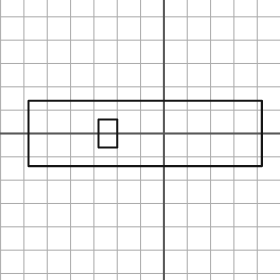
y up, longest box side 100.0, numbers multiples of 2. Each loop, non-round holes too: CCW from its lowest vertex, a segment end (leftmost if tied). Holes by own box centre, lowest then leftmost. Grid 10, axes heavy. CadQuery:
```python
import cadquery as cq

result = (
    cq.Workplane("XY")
    .moveTo(-58.0, -14.0)
    .lineTo(42.0, -14.0)
    .lineTo(42.0, 14.0)
    .lineTo(-58.0, 14.0)
    .close()
    .moveTo(-28.0, -6.0)
    .lineTo(-20.0, -6.0)
    .lineTo(-20.0, 6.0)
    .lineTo(-28.0, 6.0)
    .close()
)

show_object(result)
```